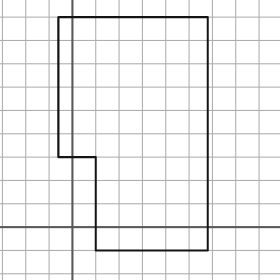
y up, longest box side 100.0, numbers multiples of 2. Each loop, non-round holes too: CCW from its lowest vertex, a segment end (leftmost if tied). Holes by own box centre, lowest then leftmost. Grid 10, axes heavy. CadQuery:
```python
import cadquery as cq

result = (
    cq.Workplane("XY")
    .moveTo(10.0, -10.0)
    .lineTo(58.0, -10.0)
    .lineTo(58.0, 90.0)
    .lineTo(-6.0, 90.0)
    .lineTo(-6.0, 30.0)
    .lineTo(10.0, 30.0)
    .close()
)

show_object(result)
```